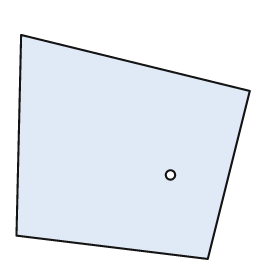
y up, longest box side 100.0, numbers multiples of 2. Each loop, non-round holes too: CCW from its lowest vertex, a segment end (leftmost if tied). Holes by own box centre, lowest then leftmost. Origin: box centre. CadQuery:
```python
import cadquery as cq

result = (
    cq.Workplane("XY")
    .moveTo(32.0, -48.0)
    .lineTo(50.0, 24.0)
    .lineTo(-48.0, 48.0)
    .lineTo(-50.0, -38.0)
    .close()
    .moveTo(16.0, -12.0)
    .circle(2.0)
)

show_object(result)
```